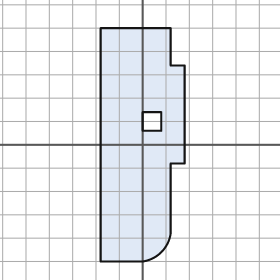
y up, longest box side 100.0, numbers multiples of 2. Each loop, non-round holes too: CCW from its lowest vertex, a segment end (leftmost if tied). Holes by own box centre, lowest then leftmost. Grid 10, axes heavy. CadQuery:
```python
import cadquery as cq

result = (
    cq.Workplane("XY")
    .moveTo(-18.0, -50.0)
    .lineTo(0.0, -50.0)
    .threePointArc((8.0, -46.0), (12.0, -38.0))
    .lineTo(12.0, -8.0)
    .lineTo(18.0, -8.0)
    .lineTo(18.0, 34.0)
    .lineTo(12.0, 34.0)
    .lineTo(12.0, 50.0)
    .lineTo(-18.0, 50.0)
    .close()
    .moveTo(0.0, 6.0)
    .lineTo(8.0, 6.0)
    .lineTo(8.0, 14.0)
    .lineTo(0.0, 14.0)
    .close()
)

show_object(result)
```